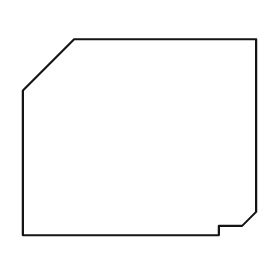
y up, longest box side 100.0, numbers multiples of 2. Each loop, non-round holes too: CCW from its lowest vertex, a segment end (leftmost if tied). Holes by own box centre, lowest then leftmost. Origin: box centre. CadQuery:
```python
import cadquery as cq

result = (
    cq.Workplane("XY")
    .moveTo(-50.0, -42.0)
    .lineTo(34.0, -42.0)
    .lineTo(34.0, -38.0)
    .lineTo(44.0, -38.0)
    .lineTo(50.0, -32.0)
    .lineTo(50.0, 42.0)
    .lineTo(-28.0, 42.0)
    .lineTo(-50.0, 20.0)
    .close()
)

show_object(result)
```